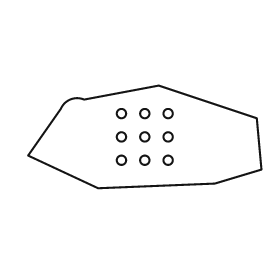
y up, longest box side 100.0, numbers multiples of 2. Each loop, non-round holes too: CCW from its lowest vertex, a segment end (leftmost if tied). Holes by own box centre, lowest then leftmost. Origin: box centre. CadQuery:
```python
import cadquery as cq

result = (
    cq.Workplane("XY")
    .moveTo(-20.0, -22.0)
    .lineTo(30.0, -20.0)
    .lineTo(50.0, -14.0)
    .lineTo(48.0, 8.0)
    .lineTo(6.0, 22.0)
    .lineTo(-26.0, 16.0)
    .threePointArc((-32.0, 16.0), (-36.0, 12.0))
    .lineTo(-50.0, -8.0)
    .close()
    .moveTo(-10.0, -10.0)
    .circle(2.0)
    .moveTo(0.0, -10.0)
    .circle(2.0)
    .moveTo(10.0, -10.0)
    .circle(2.0)
    .moveTo(-10.0, 0.0)
    .circle(2.0)
    .moveTo(0.0, 0.0)
    .circle(2.0)
    .moveTo(10.0, 0.0)
    .circle(2.0)
    .moveTo(-10.0, 10.0)
    .circle(2.0)
    .moveTo(0.0, 10.0)
    .circle(2.0)
    .moveTo(10.0, 10.0)
    .circle(2.0)
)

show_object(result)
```